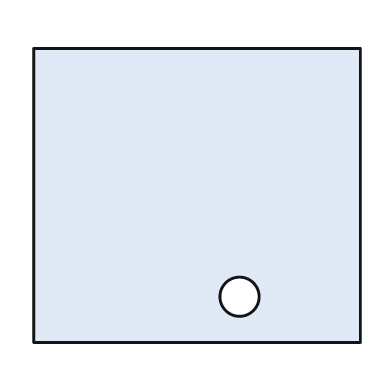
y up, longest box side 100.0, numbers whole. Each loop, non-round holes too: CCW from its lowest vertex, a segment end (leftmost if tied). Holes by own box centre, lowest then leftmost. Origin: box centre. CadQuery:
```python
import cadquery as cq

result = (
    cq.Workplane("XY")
    .moveTo(-50.0, -45.0)
    .lineTo(50.0, -45.0)
    .lineTo(50.0, 45.0)
    .lineTo(-50.0, 45.0)
    .close()
    .moveTo(13.0, -31.0)
    .circle(6.0)
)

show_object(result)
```